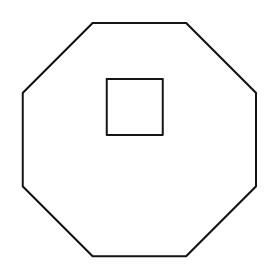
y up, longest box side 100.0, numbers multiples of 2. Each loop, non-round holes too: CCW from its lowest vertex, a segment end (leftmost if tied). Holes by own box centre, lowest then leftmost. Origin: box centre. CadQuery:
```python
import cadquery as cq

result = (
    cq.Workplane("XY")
    .moveTo(-20.0, -50.0)
    .lineTo(20.0, -50.0)
    .lineTo(50.0, -20.0)
    .lineTo(50.0, 20.0)
    .lineTo(20.0, 50.0)
    .lineTo(-20.0, 50.0)
    .lineTo(-50.0, 20.0)
    .lineTo(-50.0, -20.0)
    .close()
    .moveTo(-14.0, 2.0)
    .lineTo(10.0, 2.0)
    .lineTo(10.0, 26.0)
    .lineTo(-14.0, 26.0)
    .close()
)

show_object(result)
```